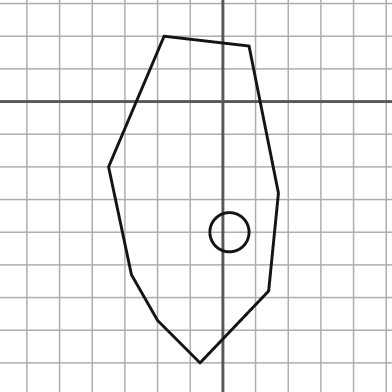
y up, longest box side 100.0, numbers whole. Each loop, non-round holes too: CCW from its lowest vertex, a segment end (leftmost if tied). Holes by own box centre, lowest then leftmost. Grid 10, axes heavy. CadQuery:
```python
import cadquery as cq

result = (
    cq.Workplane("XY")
    .moveTo(-7.0, -80.0)
    .lineTo(14.0, -58.0)
    .lineTo(17.0, -28.0)
    .lineTo(8.0, 17.0)
    .lineTo(-18.0, 20.0)
    .lineTo(-35.0, -20.0)
    .lineTo(-28.0, -53.0)
    .lineTo(-20.0, -67.0)
    .close()
    .moveTo(2.0, -40.0)
    .circle(6.0)
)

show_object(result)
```